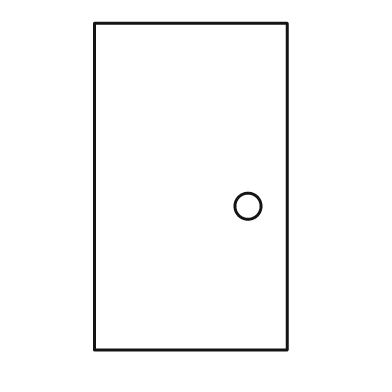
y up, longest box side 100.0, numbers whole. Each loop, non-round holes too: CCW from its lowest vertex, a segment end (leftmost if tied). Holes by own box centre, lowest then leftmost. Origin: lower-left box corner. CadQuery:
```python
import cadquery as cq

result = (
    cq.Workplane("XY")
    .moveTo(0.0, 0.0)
    .lineTo(59.0, 0.0)
    .lineTo(59.0, 100.0)
    .lineTo(0.0, 100.0)
    .close()
    .moveTo(47.0, 44.0)
    .circle(4.0)
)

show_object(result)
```